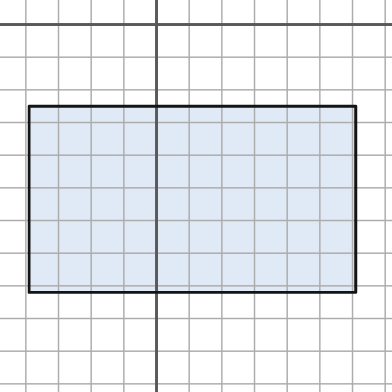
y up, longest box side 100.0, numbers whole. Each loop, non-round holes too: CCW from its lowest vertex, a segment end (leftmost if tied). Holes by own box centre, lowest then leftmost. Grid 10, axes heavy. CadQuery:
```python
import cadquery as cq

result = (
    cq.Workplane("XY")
    .moveTo(-39.0, -82.0)
    .lineTo(61.0, -82.0)
    .lineTo(61.0, -25.0)
    .lineTo(-39.0, -25.0)
    .close()
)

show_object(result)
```